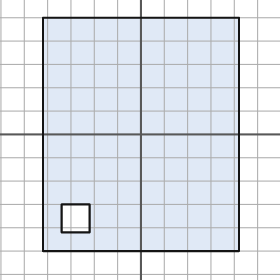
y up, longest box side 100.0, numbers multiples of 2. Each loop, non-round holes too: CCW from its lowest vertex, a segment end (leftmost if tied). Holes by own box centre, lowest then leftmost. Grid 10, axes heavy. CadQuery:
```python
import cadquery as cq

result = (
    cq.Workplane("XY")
    .moveTo(-42.0, -50.0)
    .lineTo(42.0, -50.0)
    .lineTo(42.0, 50.0)
    .lineTo(-42.0, 50.0)
    .close()
    .moveTo(-34.0, -42.0)
    .lineTo(-22.0, -42.0)
    .lineTo(-22.0, -30.0)
    .lineTo(-34.0, -30.0)
    .close()
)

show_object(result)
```